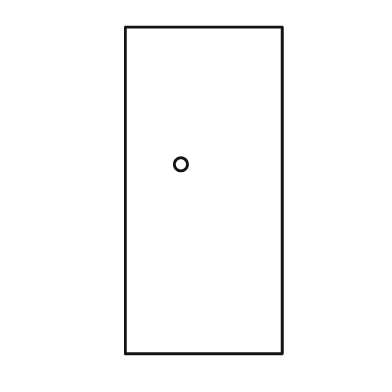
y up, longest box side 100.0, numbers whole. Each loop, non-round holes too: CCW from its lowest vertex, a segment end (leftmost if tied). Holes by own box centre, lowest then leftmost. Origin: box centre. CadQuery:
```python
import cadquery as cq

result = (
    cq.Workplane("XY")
    .moveTo(-24.0, -50.0)
    .lineTo(24.0, -50.0)
    .lineTo(24.0, 50.0)
    .lineTo(-24.0, 50.0)
    .close()
    .moveTo(-7.0, 8.0)
    .circle(2.0)
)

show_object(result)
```